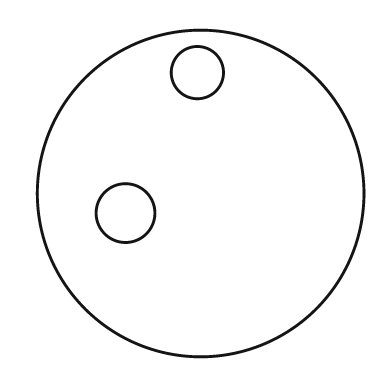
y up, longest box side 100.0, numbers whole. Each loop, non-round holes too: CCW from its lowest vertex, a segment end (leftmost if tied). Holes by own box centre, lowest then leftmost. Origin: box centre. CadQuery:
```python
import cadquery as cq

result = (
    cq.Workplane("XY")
    .moveTo(0.0, 0.0)
    .circle(50.0)
    .moveTo(-23.0, -6.0)
    .circle(9.0)
    .moveTo(-1.0, 37.0)
    .circle(8.0)
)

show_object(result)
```